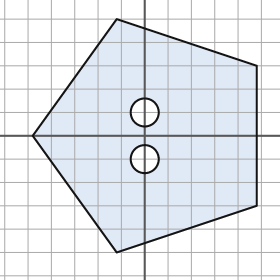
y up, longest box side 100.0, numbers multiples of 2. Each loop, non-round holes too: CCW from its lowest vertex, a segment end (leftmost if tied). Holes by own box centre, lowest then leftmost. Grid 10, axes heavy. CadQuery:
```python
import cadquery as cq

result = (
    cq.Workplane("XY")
    .moveTo(-12.0, -50.0)
    .lineTo(48.0, -30.0)
    .lineTo(48.0, 30.0)
    .lineTo(-12.0, 50.0)
    .lineTo(-48.0, 0.0)
    .close()
    .moveTo(0.0, -10.0)
    .circle(6.0)
    .moveTo(0.0, 10.0)
    .circle(6.0)
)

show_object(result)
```